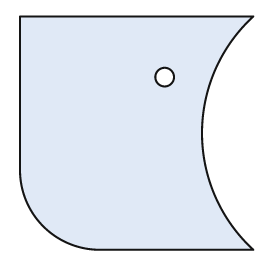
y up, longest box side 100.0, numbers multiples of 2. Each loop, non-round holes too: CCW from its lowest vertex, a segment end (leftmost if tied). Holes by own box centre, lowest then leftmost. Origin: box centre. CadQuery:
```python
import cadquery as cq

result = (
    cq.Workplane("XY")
    .moveTo(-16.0, -50.0)
    .lineTo(50.0, -50.0)
    .threePointArc((28.0, 0.0), (50.0, 50.0))
    .lineTo(-50.0, 50.0)
    .lineTo(-50.0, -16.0)
    .threePointArc((-40.0, -40.0), (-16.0, -50.0))
    .close()
    .moveTo(12.0, 24.0)
    .circle(4.0)
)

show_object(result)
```